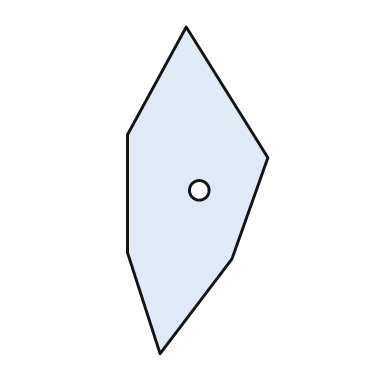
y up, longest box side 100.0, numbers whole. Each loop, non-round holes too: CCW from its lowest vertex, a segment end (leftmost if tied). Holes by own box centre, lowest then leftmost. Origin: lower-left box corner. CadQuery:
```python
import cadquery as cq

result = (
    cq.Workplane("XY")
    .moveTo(10.0, 0.0)
    .lineTo(32.0, 29.0)
    .lineTo(43.0, 60.0)
    .lineTo(18.0, 100.0)
    .lineTo(0.0, 67.0)
    .lineTo(0.0, 31.0)
    .close()
    .moveTo(22.0, 50.0)
    .circle(3.0)
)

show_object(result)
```